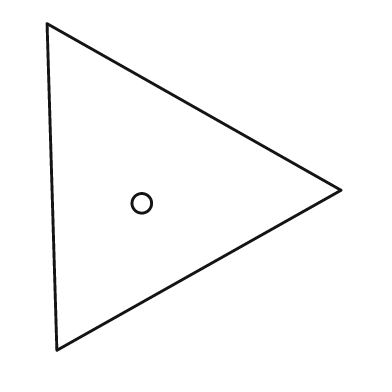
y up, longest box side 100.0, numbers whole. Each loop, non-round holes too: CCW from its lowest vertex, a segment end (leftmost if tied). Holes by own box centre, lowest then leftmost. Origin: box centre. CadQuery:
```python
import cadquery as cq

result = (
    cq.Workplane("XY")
    .moveTo(-42.0, -50.0)
    .lineTo(45.0, -1.0)
    .lineTo(-45.0, 50.0)
    .close()
    .moveTo(-16.0, -5.0)
    .circle(3.0)
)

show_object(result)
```